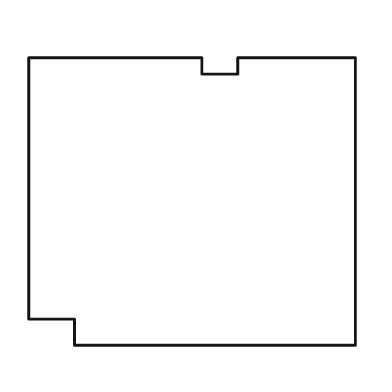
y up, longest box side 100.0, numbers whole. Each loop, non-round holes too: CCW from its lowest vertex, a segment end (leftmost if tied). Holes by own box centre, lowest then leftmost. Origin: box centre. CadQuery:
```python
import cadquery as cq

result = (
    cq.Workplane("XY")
    .moveTo(-36.0, -44.0)
    .lineTo(50.0, -44.0)
    .lineTo(50.0, 44.0)
    .lineTo(14.0, 44.0)
    .lineTo(14.0, 39.0)
    .lineTo(3.0, 39.0)
    .lineTo(3.0, 44.0)
    .lineTo(-50.0, 44.0)
    .lineTo(-50.0, -36.0)
    .lineTo(-36.0, -36.0)
    .close()
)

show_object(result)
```